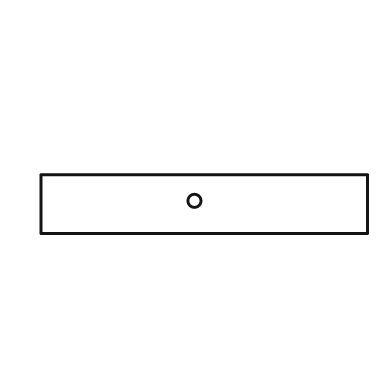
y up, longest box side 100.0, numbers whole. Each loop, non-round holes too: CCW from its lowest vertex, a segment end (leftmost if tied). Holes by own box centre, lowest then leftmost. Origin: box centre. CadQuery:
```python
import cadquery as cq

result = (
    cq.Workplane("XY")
    .moveTo(-50.0, -9.0)
    .lineTo(50.0, -9.0)
    .lineTo(50.0, 9.0)
    .lineTo(-50.0, 9.0)
    .close()
    .moveTo(-3.0, 1.0)
    .circle(2.0)
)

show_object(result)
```